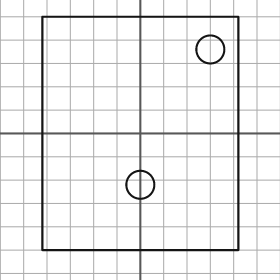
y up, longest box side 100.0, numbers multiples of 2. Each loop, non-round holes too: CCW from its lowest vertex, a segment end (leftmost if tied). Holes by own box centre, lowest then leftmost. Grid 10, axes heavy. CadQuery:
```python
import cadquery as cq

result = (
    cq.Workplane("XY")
    .moveTo(-42.0, -50.0)
    .lineTo(42.0, -50.0)
    .lineTo(42.0, 50.0)
    .lineTo(-42.0, 50.0)
    .close()
    .moveTo(0.0, -22.0)
    .circle(6.0)
    .moveTo(30.0, 36.0)
    .circle(6.0)
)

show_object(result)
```